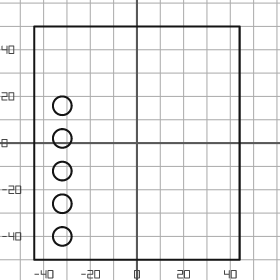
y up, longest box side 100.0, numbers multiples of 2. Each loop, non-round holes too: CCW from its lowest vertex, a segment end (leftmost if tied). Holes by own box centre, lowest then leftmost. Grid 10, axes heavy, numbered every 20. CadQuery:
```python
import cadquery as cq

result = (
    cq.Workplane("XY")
    .moveTo(-44.0, -50.0)
    .lineTo(44.0, -50.0)
    .lineTo(44.0, 50.0)
    .lineTo(-44.0, 50.0)
    .close()
    .moveTo(-32.0, -40.0)
    .circle(4.0)
    .moveTo(-32.0, -26.0)
    .circle(4.0)
    .moveTo(-32.0, -12.0)
    .circle(4.0)
    .moveTo(-32.0, 2.0)
    .circle(4.0)
    .moveTo(-32.0, 16.0)
    .circle(4.0)
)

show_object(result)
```